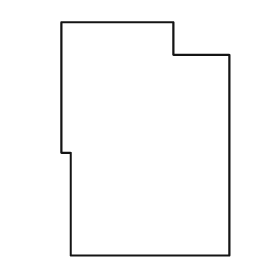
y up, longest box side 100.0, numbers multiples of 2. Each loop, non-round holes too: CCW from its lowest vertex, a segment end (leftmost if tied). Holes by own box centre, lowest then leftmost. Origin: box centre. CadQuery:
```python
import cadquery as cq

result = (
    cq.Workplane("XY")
    .moveTo(-32.0, -50.0)
    .lineTo(36.0, -50.0)
    .lineTo(36.0, 36.0)
    .lineTo(12.0, 36.0)
    .lineTo(12.0, 50.0)
    .lineTo(-36.0, 50.0)
    .lineTo(-36.0, -6.0)
    .lineTo(-32.0, -6.0)
    .close()
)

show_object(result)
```